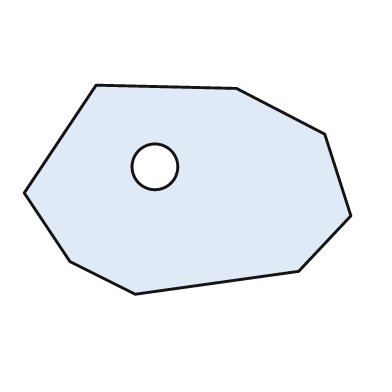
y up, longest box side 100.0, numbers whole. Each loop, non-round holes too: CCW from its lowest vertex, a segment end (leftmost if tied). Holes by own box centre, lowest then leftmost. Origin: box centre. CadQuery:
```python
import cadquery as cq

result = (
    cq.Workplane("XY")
    .moveTo(-16.0, -32.0)
    .lineTo(34.0, -25.0)
    .lineTo(50.0, -8.0)
    .lineTo(42.0, 17.0)
    .lineTo(15.0, 31.0)
    .lineTo(-28.0, 32.0)
    .lineTo(-50.0, -1.0)
    .lineTo(-36.0, -22.0)
    .close()
    .moveTo(-10.0, 7.0)
    .circle(7.0)
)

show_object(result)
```